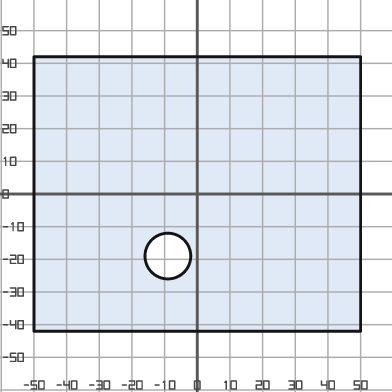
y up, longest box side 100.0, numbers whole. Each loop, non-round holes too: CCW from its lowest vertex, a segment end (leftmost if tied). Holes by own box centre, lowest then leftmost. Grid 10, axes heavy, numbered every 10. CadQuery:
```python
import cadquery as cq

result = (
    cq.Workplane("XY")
    .moveTo(-50.0, -42.0)
    .lineTo(50.0, -42.0)
    .lineTo(50.0, 42.0)
    .lineTo(-50.0, 42.0)
    .close()
    .moveTo(-9.0, -19.0)
    .circle(7.0)
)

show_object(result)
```